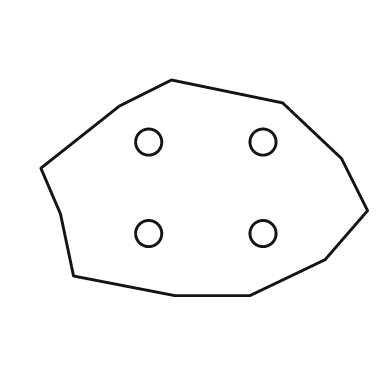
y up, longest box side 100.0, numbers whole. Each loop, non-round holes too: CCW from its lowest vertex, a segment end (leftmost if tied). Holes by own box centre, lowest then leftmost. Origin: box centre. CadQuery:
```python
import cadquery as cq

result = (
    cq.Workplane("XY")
    .moveTo(-9.0, -33.0)
    .lineTo(14.0, -33.0)
    .lineTo(37.0, -22.0)
    .lineTo(50.0, -7.0)
    .lineTo(42.0, 9.0)
    .lineTo(24.0, 26.0)
    .lineTo(-10.0, 33.0)
    .lineTo(-26.0, 25.0)
    .lineTo(-50.0, 6.0)
    .lineTo(-44.0, -8.0)
    .lineTo(-40.0, -27.0)
    .close()
    .moveTo(-17.0, -14.0)
    .circle(4.0)
    .moveTo(18.0, -14.0)
    .circle(4.0)
    .moveTo(-17.0, 14.0)
    .circle(4.0)
    .moveTo(18.0, 14.0)
    .circle(4.0)
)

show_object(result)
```